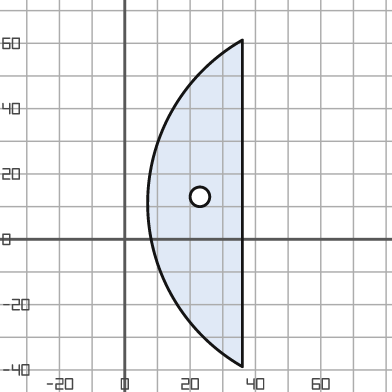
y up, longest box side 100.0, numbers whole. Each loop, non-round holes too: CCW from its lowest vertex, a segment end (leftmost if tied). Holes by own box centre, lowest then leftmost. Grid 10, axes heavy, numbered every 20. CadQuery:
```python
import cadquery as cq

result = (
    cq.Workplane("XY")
    .moveTo(36.0, -39.0)
    .lineTo(36.0, 61.0)
    .threePointArc((7.0, 11.0), (36.0, -39.0))
    .close()
    .moveTo(23.0, 13.0)
    .circle(3.0)
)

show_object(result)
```